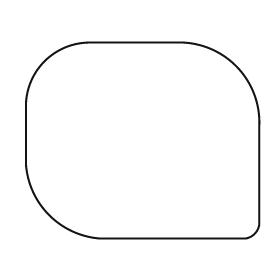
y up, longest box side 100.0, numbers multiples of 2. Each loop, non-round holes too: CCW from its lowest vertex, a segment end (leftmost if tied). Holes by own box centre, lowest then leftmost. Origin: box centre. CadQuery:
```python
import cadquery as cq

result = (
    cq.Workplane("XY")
    .moveTo(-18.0, -42.0)
    .lineTo(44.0, -42.0)
    .threePointArc((48.0, -40.0), (50.0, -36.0))
    .lineTo(50.0, 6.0)
    .threePointArc((40.0, 32.0), (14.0, 42.0))
    .lineTo(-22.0, 42.0)
    .threePointArc((-42.0, 34.0), (-50.0, 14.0))
    .lineTo(-50.0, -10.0)
    .threePointArc((-40.0, -32.0), (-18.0, -42.0))
    .close()
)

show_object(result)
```